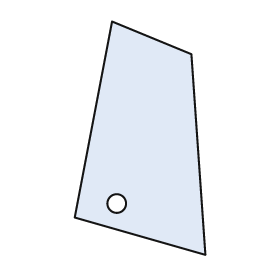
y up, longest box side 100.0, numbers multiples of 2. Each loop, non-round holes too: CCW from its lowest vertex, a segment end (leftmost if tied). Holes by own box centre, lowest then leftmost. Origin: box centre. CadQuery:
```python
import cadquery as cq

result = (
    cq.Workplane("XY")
    .moveTo(28.0, -50.0)
    .lineTo(22.0, 36.0)
    .lineTo(-12.0, 50.0)
    .lineTo(-28.0, -34.0)
    .close()
    .moveTo(-10.0, -28.0)
    .circle(4.0)
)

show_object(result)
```